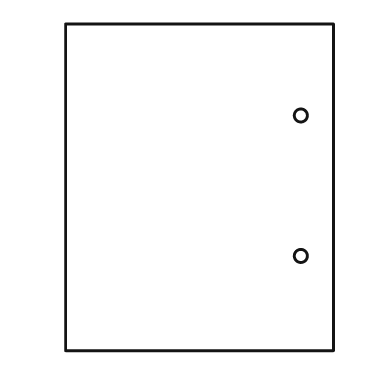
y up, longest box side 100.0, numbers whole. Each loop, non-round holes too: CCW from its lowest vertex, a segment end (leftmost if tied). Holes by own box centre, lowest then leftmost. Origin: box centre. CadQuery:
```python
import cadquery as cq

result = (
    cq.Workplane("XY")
    .moveTo(-41.0, -50.0)
    .lineTo(41.0, -50.0)
    .lineTo(41.0, 50.0)
    .lineTo(-41.0, 50.0)
    .close()
    .moveTo(31.0, -21.0)
    .circle(2.0)
    .moveTo(31.0, 22.0)
    .circle(2.0)
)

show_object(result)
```